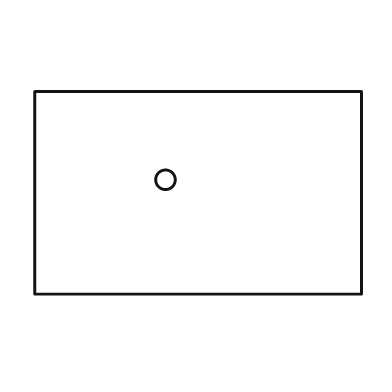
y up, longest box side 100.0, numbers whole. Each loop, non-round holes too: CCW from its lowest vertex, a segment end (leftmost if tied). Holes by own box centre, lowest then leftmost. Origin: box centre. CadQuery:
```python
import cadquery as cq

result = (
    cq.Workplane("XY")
    .moveTo(-50.0, -31.0)
    .lineTo(50.0, -31.0)
    .lineTo(50.0, 31.0)
    .lineTo(-50.0, 31.0)
    .close()
    .moveTo(-10.0, 4.0)
    .circle(3.0)
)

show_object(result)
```